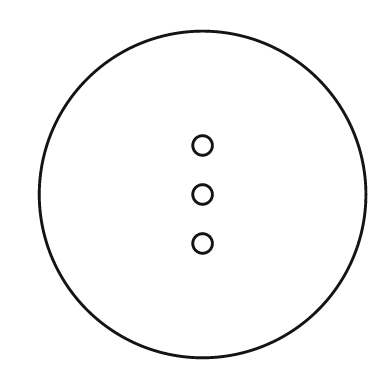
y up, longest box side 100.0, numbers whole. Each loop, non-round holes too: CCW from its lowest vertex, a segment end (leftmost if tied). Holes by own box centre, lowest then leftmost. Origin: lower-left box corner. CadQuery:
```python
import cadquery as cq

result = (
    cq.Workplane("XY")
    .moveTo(50.0, 50.0)
    .circle(50.0)
    .moveTo(50.0, 35.0)
    .circle(3.0)
    .moveTo(50.0, 50.0)
    .circle(3.0)
    .moveTo(50.0, 65.0)
    .circle(3.0)
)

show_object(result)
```